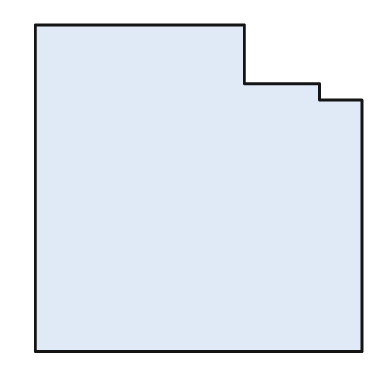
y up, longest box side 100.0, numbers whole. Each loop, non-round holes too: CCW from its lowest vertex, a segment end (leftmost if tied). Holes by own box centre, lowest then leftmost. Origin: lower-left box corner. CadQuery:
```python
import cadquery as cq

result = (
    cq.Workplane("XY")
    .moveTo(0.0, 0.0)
    .lineTo(100.0, 0.0)
    .lineTo(100.0, 77.0)
    .lineTo(87.0, 77.0)
    .lineTo(87.0, 82.0)
    .lineTo(64.0, 82.0)
    .lineTo(64.0, 100.0)
    .lineTo(0.0, 100.0)
    .close()
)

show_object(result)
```